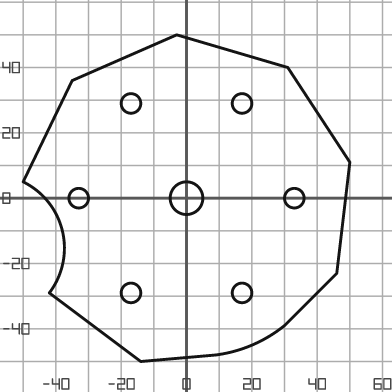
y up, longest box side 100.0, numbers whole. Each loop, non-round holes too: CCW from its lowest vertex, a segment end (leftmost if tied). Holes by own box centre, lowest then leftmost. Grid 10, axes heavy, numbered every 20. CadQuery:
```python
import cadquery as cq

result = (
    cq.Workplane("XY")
    .moveTo(-14.0, -50.0)
    .lineTo(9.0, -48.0)
    .threePointArc((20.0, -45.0), (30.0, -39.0))
    .lineTo(46.0, -23.0)
    .lineTo(50.0, 11.0)
    .lineTo(31.0, 40.0)
    .lineTo(-3.0, 50.0)
    .lineTo(-35.0, 36.0)
    .lineTo(-50.0, 5.0)
    .threePointArc((-38.0, -10.0), (-42.0, -29.0))
    .close()
    .moveTo(-17.0, -29.0)
    .circle(3.0)
    .moveTo(17.0, -29.0)
    .circle(3.0)
    .moveTo(-33.0, 0.0)
    .circle(3.0)
    .moveTo(0.0, 0.0)
    .circle(5.0)
    .moveTo(33.0, 0.0)
    .circle(3.0)
    .moveTo(-17.0, 29.0)
    .circle(3.0)
    .moveTo(17.0, 29.0)
    .circle(3.0)
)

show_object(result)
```